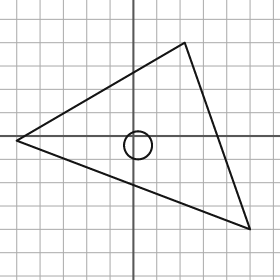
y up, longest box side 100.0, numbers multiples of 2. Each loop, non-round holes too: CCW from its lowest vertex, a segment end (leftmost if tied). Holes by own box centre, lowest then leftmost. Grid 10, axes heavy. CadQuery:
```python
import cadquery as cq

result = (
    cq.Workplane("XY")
    .moveTo(50.0, -40.0)
    .lineTo(22.0, 40.0)
    .lineTo(-50.0, -2.0)
    .close()
    .moveTo(2.0, -4.0)
    .circle(6.0)
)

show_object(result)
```